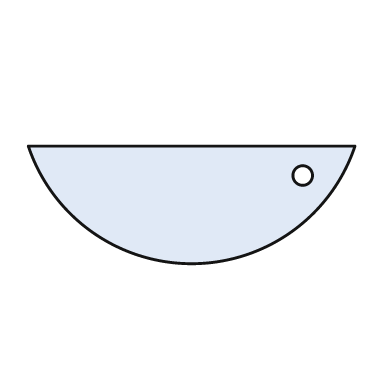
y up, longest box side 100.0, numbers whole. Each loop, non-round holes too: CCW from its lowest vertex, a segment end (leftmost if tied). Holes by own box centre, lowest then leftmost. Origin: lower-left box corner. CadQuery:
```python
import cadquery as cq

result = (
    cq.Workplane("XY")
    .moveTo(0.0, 36.0)
    .threePointArc((50.0, 0.0), (100.0, 36.0))
    .close()
    .moveTo(84.0, 27.0)
    .circle(3.0)
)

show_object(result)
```